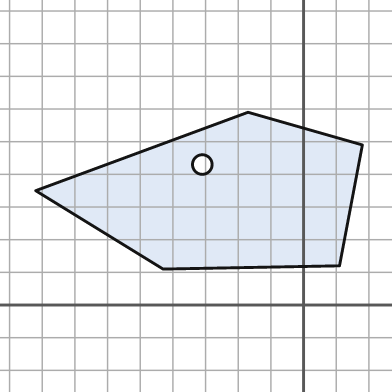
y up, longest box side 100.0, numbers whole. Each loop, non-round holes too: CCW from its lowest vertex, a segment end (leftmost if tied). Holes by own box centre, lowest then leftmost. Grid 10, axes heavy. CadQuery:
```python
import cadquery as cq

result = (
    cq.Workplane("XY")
    .moveTo(-43.0, 11.0)
    .lineTo(11.0, 12.0)
    .lineTo(18.0, 49.0)
    .lineTo(-17.0, 59.0)
    .lineTo(-82.0, 35.0)
    .close()
    .moveTo(-31.0, 43.0)
    .circle(3.0)
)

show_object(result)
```